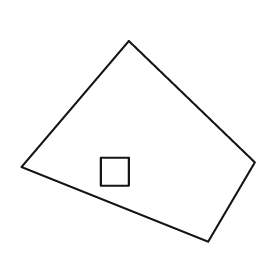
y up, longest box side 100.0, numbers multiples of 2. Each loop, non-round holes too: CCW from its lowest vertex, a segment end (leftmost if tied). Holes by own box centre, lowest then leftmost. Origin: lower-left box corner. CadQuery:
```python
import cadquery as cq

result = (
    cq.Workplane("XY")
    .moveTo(80.0, 0.0)
    .lineTo(100.0, 34.0)
    .lineTo(46.0, 86.0)
    .lineTo(0.0, 32.0)
    .close()
    .moveTo(34.0, 24.0)
    .lineTo(46.0, 24.0)
    .lineTo(46.0, 36.0)
    .lineTo(34.0, 36.0)
    .close()
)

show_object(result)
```